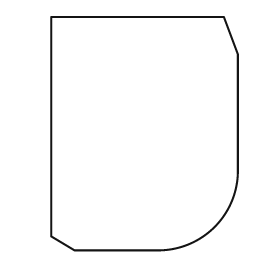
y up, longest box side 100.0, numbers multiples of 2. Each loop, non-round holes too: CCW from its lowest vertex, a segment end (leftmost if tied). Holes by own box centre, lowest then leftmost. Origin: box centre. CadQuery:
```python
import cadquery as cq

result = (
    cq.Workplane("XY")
    .moveTo(-30.0, -50.0)
    .lineTo(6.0, -50.0)
    .threePointArc((30.0, -40.0), (40.0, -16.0))
    .lineTo(40.0, 34.0)
    .lineTo(34.0, 50.0)
    .lineTo(-40.0, 50.0)
    .lineTo(-40.0, -44.0)
    .close()
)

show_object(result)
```